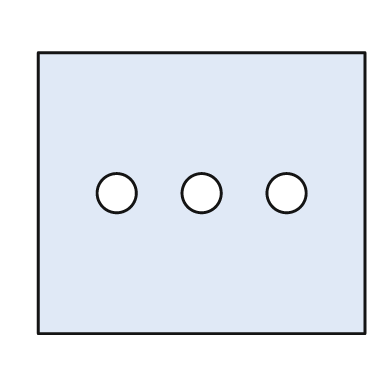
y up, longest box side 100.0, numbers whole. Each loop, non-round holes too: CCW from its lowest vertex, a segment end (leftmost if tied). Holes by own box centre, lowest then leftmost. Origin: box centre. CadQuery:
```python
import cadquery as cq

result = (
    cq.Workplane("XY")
    .moveTo(-50.0, -43.0)
    .lineTo(50.0, -43.0)
    .lineTo(50.0, 43.0)
    .lineTo(-50.0, 43.0)
    .close()
    .moveTo(-26.0, 0.0)
    .circle(6.0)
    .moveTo(0.0, 0.0)
    .circle(6.0)
    .moveTo(26.0, 0.0)
    .circle(6.0)
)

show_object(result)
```